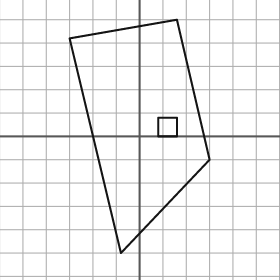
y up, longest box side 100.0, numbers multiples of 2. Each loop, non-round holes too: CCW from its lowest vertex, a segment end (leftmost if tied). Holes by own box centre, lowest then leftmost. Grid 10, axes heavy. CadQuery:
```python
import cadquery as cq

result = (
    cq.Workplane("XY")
    .moveTo(-8.0, -50.0)
    .lineTo(30.0, -10.0)
    .lineTo(16.0, 50.0)
    .lineTo(-30.0, 42.0)
    .close()
    .moveTo(8.0, 0.0)
    .lineTo(16.0, 0.0)
    .lineTo(16.0, 8.0)
    .lineTo(8.0, 8.0)
    .close()
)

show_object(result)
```